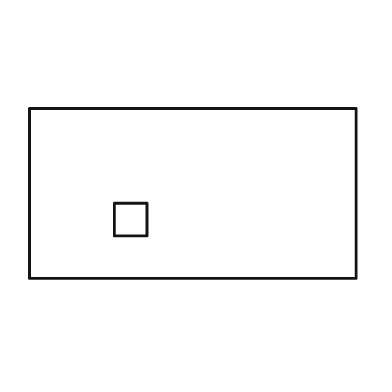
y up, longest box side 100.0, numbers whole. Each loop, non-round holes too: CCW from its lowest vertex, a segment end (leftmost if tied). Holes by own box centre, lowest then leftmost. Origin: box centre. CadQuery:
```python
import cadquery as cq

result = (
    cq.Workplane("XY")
    .moveTo(-50.0, -26.0)
    .lineTo(50.0, -26.0)
    .lineTo(50.0, 26.0)
    .lineTo(-50.0, 26.0)
    .close()
    .moveTo(-24.0, -13.0)
    .lineTo(-14.0, -13.0)
    .lineTo(-14.0, -3.0)
    .lineTo(-24.0, -3.0)
    .close()
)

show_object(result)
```